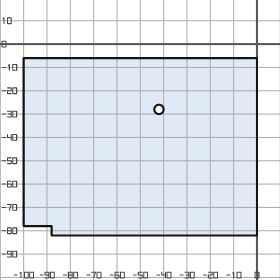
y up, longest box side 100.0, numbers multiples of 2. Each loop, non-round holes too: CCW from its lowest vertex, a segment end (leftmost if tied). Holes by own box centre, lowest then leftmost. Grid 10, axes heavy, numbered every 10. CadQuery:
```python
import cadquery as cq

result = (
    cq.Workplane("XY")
    .moveTo(-88.0, -82.0)
    .lineTo(0.0, -82.0)
    .lineTo(0.0, -6.0)
    .lineTo(-100.0, -6.0)
    .lineTo(-100.0, -78.0)
    .lineTo(-88.0, -78.0)
    .close()
    .moveTo(-42.0, -28.0)
    .circle(2.0)
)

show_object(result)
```